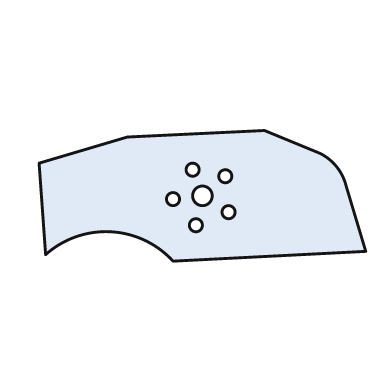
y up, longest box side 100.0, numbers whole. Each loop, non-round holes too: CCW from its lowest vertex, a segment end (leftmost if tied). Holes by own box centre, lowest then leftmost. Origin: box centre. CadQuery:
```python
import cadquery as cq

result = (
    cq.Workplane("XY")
    .moveTo(-9.0, -20.0)
    .lineTo(50.0, -17.0)
    .lineTo(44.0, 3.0)
    .threePointArc((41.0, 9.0), (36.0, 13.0))
    .lineTo(19.0, 20.0)
    .lineTo(-23.0, 18.0)
    .lineTo(-50.0, 10.0)
    .lineTo(-48.0, -18.0)
    .threePointArc((-28.0, -11.0), (-9.0, -20.0))
    .close()
    .moveTo(-2.0, -9.0)
    .circle(2.0)
    .moveTo(8.0, -5.0)
    .circle(2.0)
    .moveTo(-9.0, -1.0)
    .circle(2.0)
    .moveTo(0.0, 0.0)
    .circle(3.0)
    .moveTo(7.0, 6.0)
    .circle(2.0)
    .moveTo(-3.0, 8.0)
    .circle(2.0)
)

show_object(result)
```